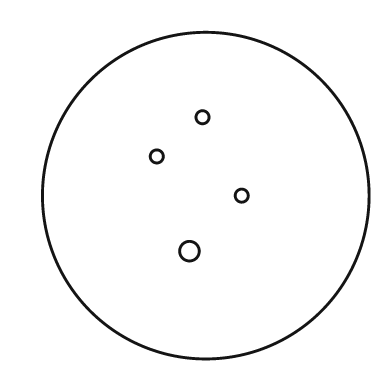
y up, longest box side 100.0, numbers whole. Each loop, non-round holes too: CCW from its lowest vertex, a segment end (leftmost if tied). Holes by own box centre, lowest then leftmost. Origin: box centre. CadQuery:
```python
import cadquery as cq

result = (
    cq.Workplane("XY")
    .moveTo(0.0, 0.0)
    .circle(50.0)
    .moveTo(-5.0, -17.0)
    .circle(3.0)
    .moveTo(11.0, 0.0)
    .circle(2.0)
    .moveTo(-15.0, 12.0)
    .circle(2.0)
    .moveTo(-1.0, 24.0)
    .circle(2.0)
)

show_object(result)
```